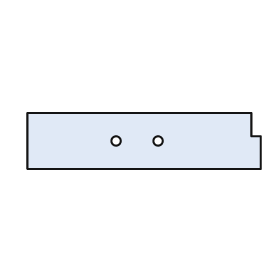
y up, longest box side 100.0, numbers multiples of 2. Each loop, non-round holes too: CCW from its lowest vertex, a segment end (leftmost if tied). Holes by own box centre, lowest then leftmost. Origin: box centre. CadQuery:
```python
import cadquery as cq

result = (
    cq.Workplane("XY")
    .moveTo(-50.0, -12.0)
    .lineTo(50.0, -12.0)
    .lineTo(50.0, 2.0)
    .lineTo(46.0, 2.0)
    .lineTo(46.0, 12.0)
    .lineTo(-50.0, 12.0)
    .close()
    .moveTo(-12.0, 0.0)
    .circle(2.0)
    .moveTo(6.0, 0.0)
    .circle(2.0)
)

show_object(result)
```